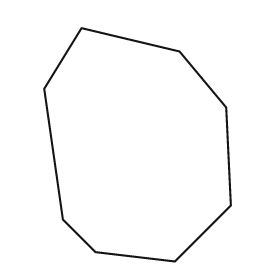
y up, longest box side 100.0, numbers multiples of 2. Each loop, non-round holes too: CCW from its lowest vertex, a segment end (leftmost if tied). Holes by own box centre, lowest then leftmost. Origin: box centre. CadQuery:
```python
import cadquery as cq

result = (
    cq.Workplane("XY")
    .moveTo(16.0, -50.0)
    .lineTo(40.0, -26.0)
    .lineTo(38.0, 16.0)
    .lineTo(18.0, 40.0)
    .lineTo(-24.0, 50.0)
    .lineTo(-40.0, 24.0)
    .lineTo(-32.0, -32.0)
    .lineTo(-18.0, -46.0)
    .close()
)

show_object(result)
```